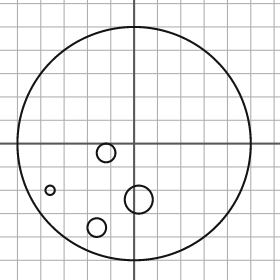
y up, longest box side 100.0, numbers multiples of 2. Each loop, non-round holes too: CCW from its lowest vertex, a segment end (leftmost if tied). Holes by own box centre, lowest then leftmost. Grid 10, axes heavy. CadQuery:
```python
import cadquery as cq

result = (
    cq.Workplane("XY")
    .moveTo(0.0, 0.0)
    .circle(50.0)
    .moveTo(-16.0, -36.0)
    .circle(4.0)
    .moveTo(2.0, -24.0)
    .circle(6.0)
    .moveTo(-36.0, -20.0)
    .circle(2.0)
    .moveTo(-12.0, -4.0)
    .circle(4.0)
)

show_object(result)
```